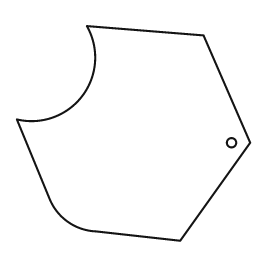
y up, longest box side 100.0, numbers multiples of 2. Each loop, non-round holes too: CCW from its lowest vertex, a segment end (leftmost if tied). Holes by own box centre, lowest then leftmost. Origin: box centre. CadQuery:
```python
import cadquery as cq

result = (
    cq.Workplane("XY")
    .moveTo(20.0, -46.0)
    .lineTo(50.0, -4.0)
    .lineTo(30.0, 42.0)
    .lineTo(-20.0, 46.0)
    .threePointArc((-22.0, 16.0), (-50.0, 6.0))
    .lineTo(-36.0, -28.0)
    .threePointArc((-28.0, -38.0), (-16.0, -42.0))
    .close()
    .moveTo(42.0, -4.0)
    .circle(2.0)
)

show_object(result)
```